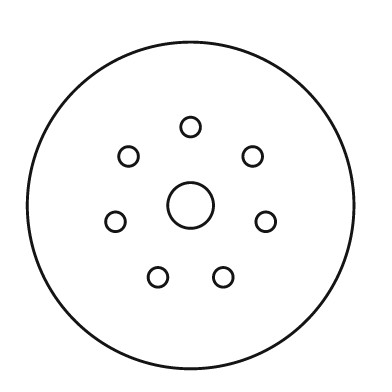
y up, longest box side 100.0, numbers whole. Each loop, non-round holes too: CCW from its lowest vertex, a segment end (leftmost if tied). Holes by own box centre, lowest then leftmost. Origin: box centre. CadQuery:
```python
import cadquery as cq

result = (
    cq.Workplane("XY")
    .moveTo(0.0, 0.0)
    .circle(50.0)
    .moveTo(-10.0, -22.0)
    .circle(3.0)
    .moveTo(10.0, -22.0)
    .circle(3.0)
    .moveTo(-23.0, -5.0)
    .circle(3.0)
    .moveTo(23.0, -5.0)
    .circle(3.0)
    .moveTo(0.0, 0.0)
    .circle(7.0)
    .moveTo(-19.0, 15.0)
    .circle(3.0)
    .moveTo(19.0, 15.0)
    .circle(3.0)
    .moveTo(0.0, 24.0)
    .circle(3.0)
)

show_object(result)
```